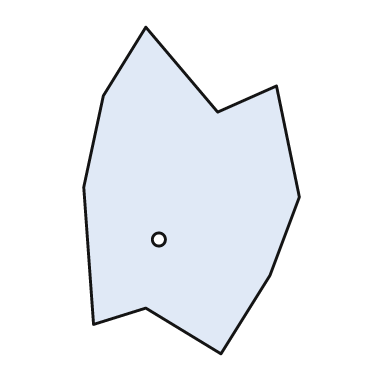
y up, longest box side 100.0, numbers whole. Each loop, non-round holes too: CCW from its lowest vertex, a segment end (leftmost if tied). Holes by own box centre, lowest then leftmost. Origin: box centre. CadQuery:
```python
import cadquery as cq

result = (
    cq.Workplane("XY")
    .moveTo(9.0, -50.0)
    .lineTo(24.0, -26.0)
    .lineTo(33.0, -2.0)
    .lineTo(26.0, 32.0)
    .lineTo(8.0, 24.0)
    .lineTo(-14.0, 50.0)
    .lineTo(-27.0, 29.0)
    .lineTo(-33.0, 1.0)
    .lineTo(-30.0, -41.0)
    .lineTo(-14.0, -36.0)
    .close()
    .moveTo(-10.0, -15.0)
    .circle(2.0)
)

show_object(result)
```